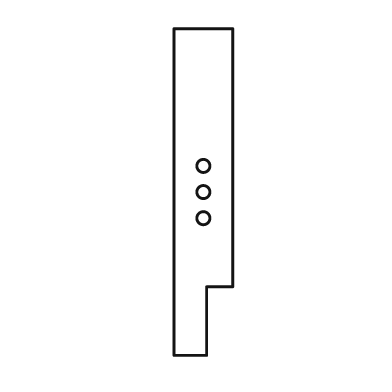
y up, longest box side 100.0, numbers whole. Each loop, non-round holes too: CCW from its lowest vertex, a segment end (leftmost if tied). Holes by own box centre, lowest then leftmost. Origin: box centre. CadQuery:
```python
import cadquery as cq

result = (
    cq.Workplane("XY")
    .moveTo(-9.0, -50.0)
    .lineTo(1.0, -50.0)
    .lineTo(1.0, -29.0)
    .lineTo(9.0, -29.0)
    .lineTo(9.0, 50.0)
    .lineTo(-9.0, 50.0)
    .close()
    .moveTo(0.0, -8.0)
    .circle(2.0)
    .moveTo(0.0, 0.0)
    .circle(2.0)
    .moveTo(0.0, 8.0)
    .circle(2.0)
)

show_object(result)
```